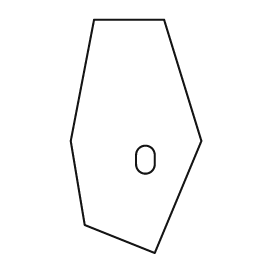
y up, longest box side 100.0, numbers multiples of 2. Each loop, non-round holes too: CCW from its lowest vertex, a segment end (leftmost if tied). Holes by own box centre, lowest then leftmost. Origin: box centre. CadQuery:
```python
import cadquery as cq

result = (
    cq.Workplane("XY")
    .moveTo(8.0, -50.0)
    .lineTo(28.0, -2.0)
    .lineTo(12.0, 50.0)
    .lineTo(-18.0, 50.0)
    .lineTo(-28.0, -2.0)
    .lineTo(-22.0, -38.0)
    .close()
    .moveTo(0.0, -12.0)
    .threePointArc((4.0, -16.0), (8.0, -12.0))
    .lineTo(8.0, -8.0)
    .threePointArc((4.0, -4.0), (0.0, -8.0))
    .close()
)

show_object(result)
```